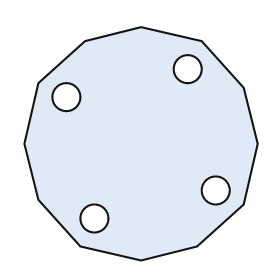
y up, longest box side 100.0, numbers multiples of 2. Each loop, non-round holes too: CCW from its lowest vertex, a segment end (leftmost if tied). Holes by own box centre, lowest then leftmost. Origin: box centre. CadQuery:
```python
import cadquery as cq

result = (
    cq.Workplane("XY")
    .moveTo(0.0, -50.0)
    .lineTo(24.0, -44.0)
    .lineTo(44.0, -26.0)
    .lineTo(50.0, 0.0)
    .lineTo(44.0, 24.0)
    .lineTo(26.0, 44.0)
    .lineTo(0.0, 50.0)
    .lineTo(-24.0, 44.0)
    .lineTo(-44.0, 26.0)
    .lineTo(-50.0, 0.0)
    .lineTo(-44.0, -24.0)
    .lineTo(-26.0, -44.0)
    .close()
    .moveTo(-20.0, -32.0)
    .circle(6.0)
    .moveTo(32.0, -20.0)
    .circle(6.0)
    .moveTo(-32.0, 20.0)
    .circle(6.0)
    .moveTo(20.0, 32.0)
    .circle(6.0)
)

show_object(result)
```